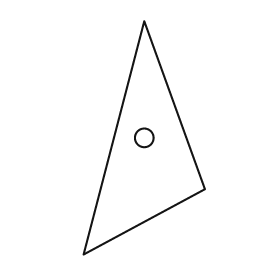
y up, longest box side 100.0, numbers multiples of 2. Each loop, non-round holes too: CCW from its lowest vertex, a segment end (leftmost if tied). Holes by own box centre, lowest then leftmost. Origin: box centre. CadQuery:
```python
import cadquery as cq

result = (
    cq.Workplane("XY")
    .moveTo(-26.0, -50.0)
    .lineTo(26.0, -22.0)
    .lineTo(0.0, 50.0)
    .close()
    .moveTo(0.0, 0.0)
    .circle(4.0)
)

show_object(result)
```